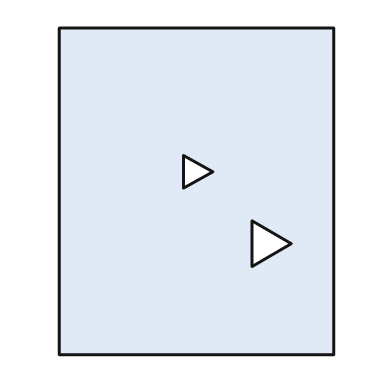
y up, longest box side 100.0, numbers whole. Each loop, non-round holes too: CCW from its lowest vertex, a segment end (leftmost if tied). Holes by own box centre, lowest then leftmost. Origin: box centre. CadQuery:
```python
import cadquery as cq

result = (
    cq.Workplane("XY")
    .moveTo(-42.0, -50.0)
    .lineTo(42.0, -50.0)
    .lineTo(42.0, 50.0)
    .lineTo(-42.0, 50.0)
    .close()
    .moveTo(17.0, -23.0)
    .lineTo(29.0, -16.0)
    .lineTo(17.0, -9.0)
    .close()
    .moveTo(-4.0, 1.0)
    .lineTo(5.0, 6.0)
    .lineTo(-4.0, 11.0)
    .close()
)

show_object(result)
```